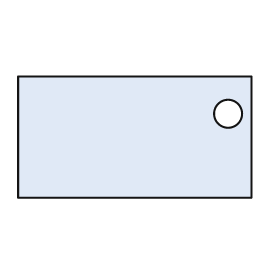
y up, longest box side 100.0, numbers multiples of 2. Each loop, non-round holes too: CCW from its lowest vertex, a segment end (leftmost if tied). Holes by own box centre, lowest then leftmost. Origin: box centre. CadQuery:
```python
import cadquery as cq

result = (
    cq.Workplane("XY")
    .moveTo(-50.0, -26.0)
    .lineTo(50.0, -26.0)
    .lineTo(50.0, 26.0)
    .lineTo(-50.0, 26.0)
    .close()
    .moveTo(40.0, 10.0)
    .circle(6.0)
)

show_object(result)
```